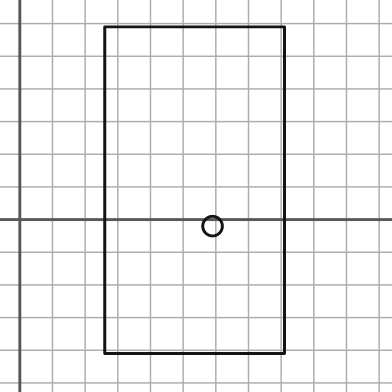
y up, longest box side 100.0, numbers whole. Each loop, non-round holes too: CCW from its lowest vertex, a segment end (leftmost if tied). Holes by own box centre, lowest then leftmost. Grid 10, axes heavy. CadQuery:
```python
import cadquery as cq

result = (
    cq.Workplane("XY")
    .moveTo(26.0, -41.0)
    .lineTo(81.0, -41.0)
    .lineTo(81.0, 59.0)
    .lineTo(26.0, 59.0)
    .close()
    .moveTo(59.0, -2.0)
    .circle(3.0)
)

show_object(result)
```